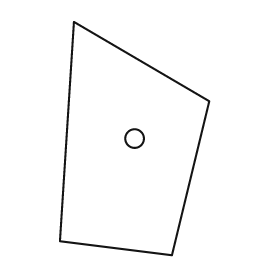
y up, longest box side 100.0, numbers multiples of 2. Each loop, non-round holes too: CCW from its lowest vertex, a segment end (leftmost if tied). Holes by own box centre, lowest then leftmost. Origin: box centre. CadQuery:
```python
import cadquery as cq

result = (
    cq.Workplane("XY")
    .moveTo(16.0, -50.0)
    .lineTo(32.0, 16.0)
    .lineTo(-26.0, 50.0)
    .lineTo(-32.0, -44.0)
    .close()
    .moveTo(0.0, 0.0)
    .circle(4.0)
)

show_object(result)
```